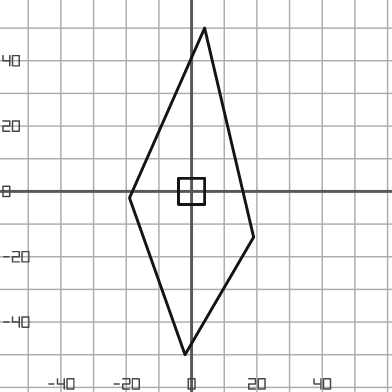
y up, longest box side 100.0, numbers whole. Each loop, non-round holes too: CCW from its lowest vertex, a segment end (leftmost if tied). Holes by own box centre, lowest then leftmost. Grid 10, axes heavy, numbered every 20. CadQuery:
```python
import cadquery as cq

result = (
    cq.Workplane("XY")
    .moveTo(-2.0, -50.0)
    .lineTo(19.0, -14.0)
    .lineTo(4.0, 50.0)
    .lineTo(-19.0, -2.0)
    .close()
    .moveTo(-4.0, -4.0)
    .lineTo(4.0, -4.0)
    .lineTo(4.0, 4.0)
    .lineTo(-4.0, 4.0)
    .close()
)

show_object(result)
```